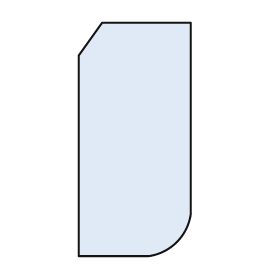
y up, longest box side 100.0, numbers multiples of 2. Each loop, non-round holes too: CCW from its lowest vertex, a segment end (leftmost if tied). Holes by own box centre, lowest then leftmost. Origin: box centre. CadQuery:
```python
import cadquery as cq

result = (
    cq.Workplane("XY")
    .moveTo(-24.0, -50.0)
    .lineTo(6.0, -50.0)
    .threePointArc((18.0, -44.0), (24.0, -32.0))
    .lineTo(24.0, 50.0)
    .lineTo(-14.0, 50.0)
    .lineTo(-24.0, 36.0)
    .close()
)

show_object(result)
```